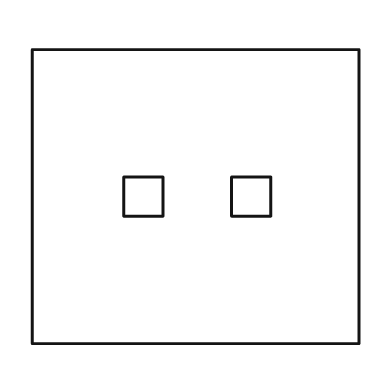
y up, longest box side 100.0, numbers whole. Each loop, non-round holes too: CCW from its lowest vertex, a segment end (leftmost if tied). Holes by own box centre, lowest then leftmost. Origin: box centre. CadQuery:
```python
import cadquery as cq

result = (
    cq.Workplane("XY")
    .moveTo(-50.0, -45.0)
    .lineTo(50.0, -45.0)
    .lineTo(50.0, 45.0)
    .lineTo(-50.0, 45.0)
    .close()
    .moveTo(-22.0, -6.0)
    .lineTo(-10.0, -6.0)
    .lineTo(-10.0, 6.0)
    .lineTo(-22.0, 6.0)
    .close()
    .moveTo(11.0, -6.0)
    .lineTo(23.0, -6.0)
    .lineTo(23.0, 6.0)
    .lineTo(11.0, 6.0)
    .close()
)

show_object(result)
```